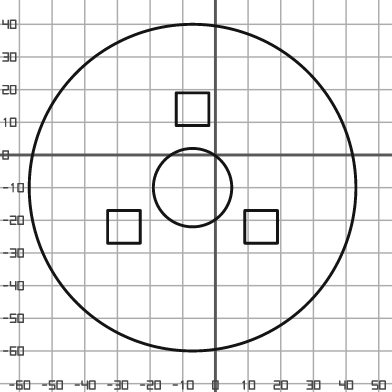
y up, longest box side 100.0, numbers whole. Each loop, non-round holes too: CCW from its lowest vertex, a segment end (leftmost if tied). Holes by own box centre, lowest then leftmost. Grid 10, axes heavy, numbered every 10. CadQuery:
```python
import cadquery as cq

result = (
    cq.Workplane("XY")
    .moveTo(-7.0, -10.0)
    .circle(50.0)
    .moveTo(-33.0, -27.0)
    .lineTo(-23.0, -27.0)
    .lineTo(-23.0, -17.0)
    .lineTo(-33.0, -17.0)
    .close()
    .moveTo(9.0, -27.0)
    .lineTo(19.0, -27.0)
    .lineTo(19.0, -17.0)
    .lineTo(9.0, -17.0)
    .close()
    .moveTo(-7.0, -10.0)
    .circle(12.0)
    .moveTo(-12.0, 9.0)
    .lineTo(-2.0, 9.0)
    .lineTo(-2.0, 19.0)
    .lineTo(-12.0, 19.0)
    .close()
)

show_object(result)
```